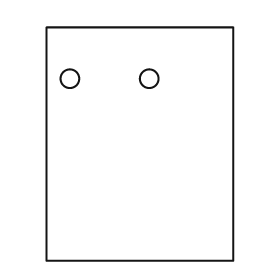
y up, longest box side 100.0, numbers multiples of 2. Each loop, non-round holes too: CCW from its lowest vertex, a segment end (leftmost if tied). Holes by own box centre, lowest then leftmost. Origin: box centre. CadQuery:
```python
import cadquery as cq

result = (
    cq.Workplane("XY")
    .moveTo(-40.0, -50.0)
    .lineTo(40.0, -50.0)
    .lineTo(40.0, 50.0)
    .lineTo(-40.0, 50.0)
    .close()
    .moveTo(-30.0, 28.0)
    .circle(4.0)
    .moveTo(4.0, 28.0)
    .circle(4.0)
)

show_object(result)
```